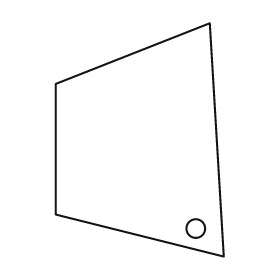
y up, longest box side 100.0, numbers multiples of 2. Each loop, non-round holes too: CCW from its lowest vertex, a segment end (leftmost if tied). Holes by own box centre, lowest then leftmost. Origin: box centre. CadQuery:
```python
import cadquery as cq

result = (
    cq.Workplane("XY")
    .moveTo(36.0, -50.0)
    .lineTo(30.0, 50.0)
    .lineTo(-36.0, 24.0)
    .lineTo(-36.0, -32.0)
    .close()
    .moveTo(24.0, -38.0)
    .circle(4.0)
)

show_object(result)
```